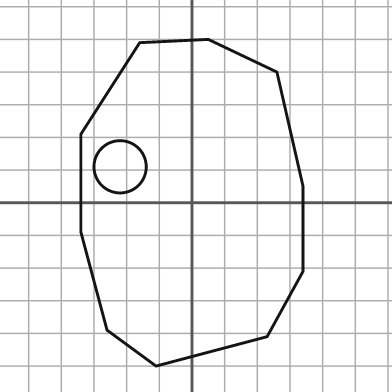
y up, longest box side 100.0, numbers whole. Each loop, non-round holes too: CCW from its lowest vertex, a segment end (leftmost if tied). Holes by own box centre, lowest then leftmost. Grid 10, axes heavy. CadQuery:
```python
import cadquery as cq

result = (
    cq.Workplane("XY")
    .moveTo(-11.0, -50.0)
    .lineTo(23.0, -41.0)
    .lineTo(34.0, -21.0)
    .lineTo(34.0, 5.0)
    .lineTo(26.0, 40.0)
    .lineTo(5.0, 50.0)
    .lineTo(-16.0, 49.0)
    .lineTo(-34.0, 21.0)
    .lineTo(-34.0, -9.0)
    .lineTo(-26.0, -39.0)
    .close()
    .moveTo(-22.0, 11.0)
    .circle(8.0)
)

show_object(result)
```